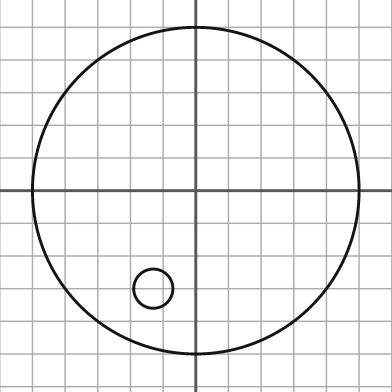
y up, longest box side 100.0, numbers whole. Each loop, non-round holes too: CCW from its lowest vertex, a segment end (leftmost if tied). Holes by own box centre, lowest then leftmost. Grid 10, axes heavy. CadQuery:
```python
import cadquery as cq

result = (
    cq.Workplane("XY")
    .moveTo(0.0, 0.0)
    .circle(50.0)
    .moveTo(-13.0, -30.0)
    .circle(6.0)
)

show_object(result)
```